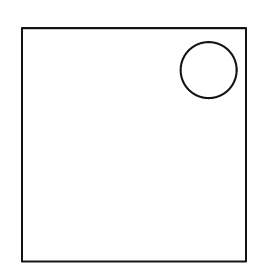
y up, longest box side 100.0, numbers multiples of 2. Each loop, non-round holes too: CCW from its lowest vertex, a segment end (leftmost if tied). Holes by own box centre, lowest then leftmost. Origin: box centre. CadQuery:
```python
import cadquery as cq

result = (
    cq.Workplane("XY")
    .moveTo(-48.0, -50.0)
    .lineTo(48.0, -50.0)
    .lineTo(48.0, 50.0)
    .lineTo(-48.0, 50.0)
    .close()
    .moveTo(32.0, 32.0)
    .circle(12.0)
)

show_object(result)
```